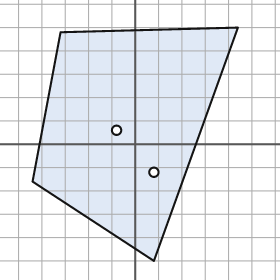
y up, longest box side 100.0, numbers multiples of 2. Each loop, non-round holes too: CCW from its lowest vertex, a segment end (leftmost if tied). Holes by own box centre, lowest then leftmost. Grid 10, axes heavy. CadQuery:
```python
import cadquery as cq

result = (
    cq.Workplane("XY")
    .moveTo(8.0, -50.0)
    .lineTo(44.0, 50.0)
    .lineTo(-32.0, 48.0)
    .lineTo(-44.0, -16.0)
    .close()
    .moveTo(8.0, -12.0)
    .circle(2.0)
    .moveTo(-8.0, 6.0)
    .circle(2.0)
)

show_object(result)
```